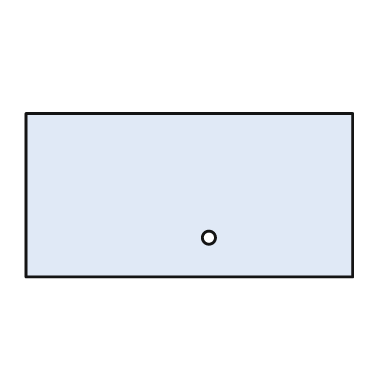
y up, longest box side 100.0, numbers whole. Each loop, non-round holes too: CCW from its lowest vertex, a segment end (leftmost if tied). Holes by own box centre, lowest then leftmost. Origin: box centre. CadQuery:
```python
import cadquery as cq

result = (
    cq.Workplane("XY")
    .moveTo(-50.0, -25.0)
    .lineTo(50.0, -25.0)
    .lineTo(50.0, 25.0)
    .lineTo(-50.0, 25.0)
    .close()
    .moveTo(6.0, -13.0)
    .circle(2.0)
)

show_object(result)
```